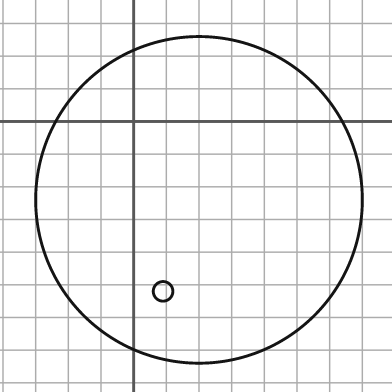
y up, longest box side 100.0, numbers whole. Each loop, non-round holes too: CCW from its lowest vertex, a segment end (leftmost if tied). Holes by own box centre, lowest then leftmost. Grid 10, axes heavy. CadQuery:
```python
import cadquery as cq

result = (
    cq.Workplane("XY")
    .moveTo(20.0, -24.0)
    .circle(50.0)
    .moveTo(9.0, -52.0)
    .circle(3.0)
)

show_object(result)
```